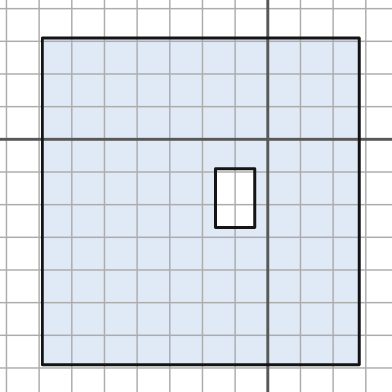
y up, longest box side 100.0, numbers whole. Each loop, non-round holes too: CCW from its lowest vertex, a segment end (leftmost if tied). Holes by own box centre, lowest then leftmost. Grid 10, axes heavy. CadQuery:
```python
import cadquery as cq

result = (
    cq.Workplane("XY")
    .moveTo(-69.0, -69.0)
    .lineTo(28.0, -69.0)
    .lineTo(28.0, 31.0)
    .lineTo(-69.0, 31.0)
    .close()
    .moveTo(-16.0, -27.0)
    .lineTo(-4.0, -27.0)
    .lineTo(-4.0, -9.0)
    .lineTo(-16.0, -9.0)
    .close()
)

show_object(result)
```